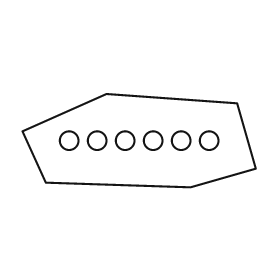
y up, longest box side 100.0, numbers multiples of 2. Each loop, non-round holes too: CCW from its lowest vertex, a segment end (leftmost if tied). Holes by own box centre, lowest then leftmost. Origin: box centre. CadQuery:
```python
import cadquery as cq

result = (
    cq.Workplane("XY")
    .moveTo(22.0, -20.0)
    .lineTo(50.0, -12.0)
    .lineTo(42.0, 16.0)
    .lineTo(-14.0, 20.0)
    .lineTo(-50.0, 4.0)
    .lineTo(-40.0, -18.0)
    .close()
    .moveTo(-30.0, 0.0)
    .circle(4.0)
    .moveTo(-18.0, 0.0)
    .circle(4.0)
    .moveTo(-6.0, 0.0)
    .circle(4.0)
    .moveTo(6.0, 0.0)
    .circle(4.0)
    .moveTo(18.0, 0.0)
    .circle(4.0)
    .moveTo(30.0, 0.0)
    .circle(4.0)
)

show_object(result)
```